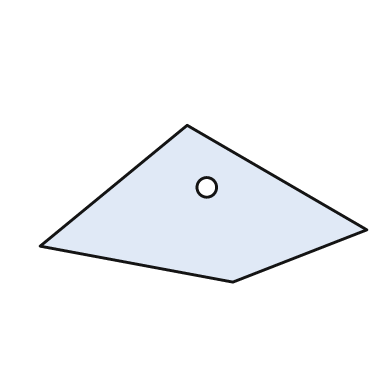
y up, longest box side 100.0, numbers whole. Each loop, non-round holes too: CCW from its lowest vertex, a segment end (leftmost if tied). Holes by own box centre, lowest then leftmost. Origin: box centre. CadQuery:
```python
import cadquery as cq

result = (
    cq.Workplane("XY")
    .moveTo(9.0, -24.0)
    .lineTo(50.0, -8.0)
    .lineTo(-5.0, 24.0)
    .lineTo(-50.0, -13.0)
    .close()
    .moveTo(1.0, 5.0)
    .circle(3.0)
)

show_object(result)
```